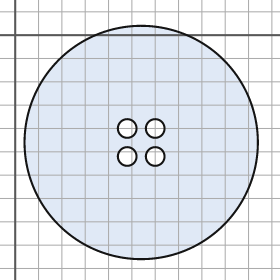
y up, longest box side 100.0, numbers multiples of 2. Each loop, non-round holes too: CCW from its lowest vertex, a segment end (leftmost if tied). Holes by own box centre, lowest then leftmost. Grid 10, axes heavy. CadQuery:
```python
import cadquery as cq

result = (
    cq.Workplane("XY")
    .moveTo(54.0, -46.0)
    .circle(50.0)
    .moveTo(48.0, -52.0)
    .circle(4.0)
    .moveTo(60.0, -52.0)
    .circle(4.0)
    .moveTo(48.0, -40.0)
    .circle(4.0)
    .moveTo(60.0, -40.0)
    .circle(4.0)
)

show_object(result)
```